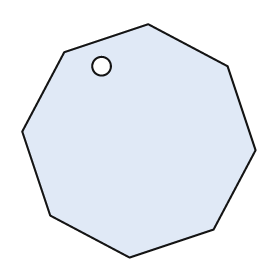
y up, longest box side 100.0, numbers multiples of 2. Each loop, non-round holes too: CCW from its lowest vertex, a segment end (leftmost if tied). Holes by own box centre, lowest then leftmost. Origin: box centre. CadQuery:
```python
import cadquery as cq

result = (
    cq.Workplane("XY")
    .moveTo(-4.0, -50.0)
    .lineTo(32.0, -38.0)
    .lineTo(50.0, -4.0)
    .lineTo(38.0, 32.0)
    .lineTo(4.0, 50.0)
    .lineTo(-32.0, 38.0)
    .lineTo(-50.0, 4.0)
    .lineTo(-38.0, -32.0)
    .close()
    .moveTo(-16.0, 32.0)
    .circle(4.0)
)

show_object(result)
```